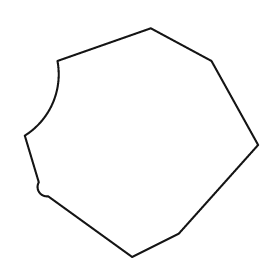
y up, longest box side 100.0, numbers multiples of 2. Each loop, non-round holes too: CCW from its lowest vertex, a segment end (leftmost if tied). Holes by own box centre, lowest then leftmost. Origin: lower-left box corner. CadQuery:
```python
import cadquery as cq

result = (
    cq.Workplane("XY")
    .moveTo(46.0, 0.0)
    .lineTo(66.0, 10.0)
    .lineTo(100.0, 48.0)
    .lineTo(80.0, 84.0)
    .lineTo(54.0, 98.0)
    .lineTo(14.0, 84.0)
    .threePointArc((12.0, 66.0), (0.0, 52.0))
    .lineTo(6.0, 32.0)
    .threePointArc((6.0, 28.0), (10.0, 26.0))
    .close()
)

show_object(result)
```